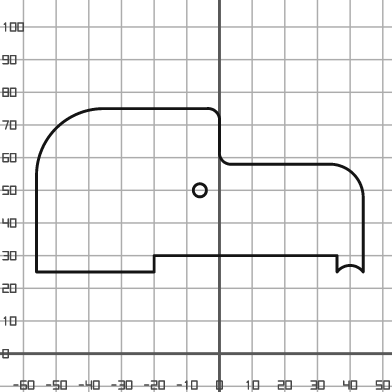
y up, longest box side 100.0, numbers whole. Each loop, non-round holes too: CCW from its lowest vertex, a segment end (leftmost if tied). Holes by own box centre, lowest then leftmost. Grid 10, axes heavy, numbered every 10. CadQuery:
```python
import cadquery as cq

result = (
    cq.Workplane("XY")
    .moveTo(-56.0, 25.0)
    .lineTo(-20.0, 25.0)
    .lineTo(-20.0, 30.0)
    .lineTo(36.0, 30.0)
    .lineTo(36.0, 25.0)
    .threePointArc((40.0, 27.0), (44.0, 25.0))
    .lineTo(44.0, 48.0)
    .threePointArc((41.0, 55.0), (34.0, 58.0))
    .lineTo(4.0, 58.0)
    .threePointArc((1.0, 59.0), (0.0, 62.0))
    .lineTo(0.0, 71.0)
    .threePointArc((-1.0, 74.0), (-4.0, 75.0))
    .lineTo(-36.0, 75.0)
    .threePointArc((-50.0, 69.0), (-56.0, 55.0))
    .close()
    .moveTo(-6.0, 50.0)
    .circle(2.0)
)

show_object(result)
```